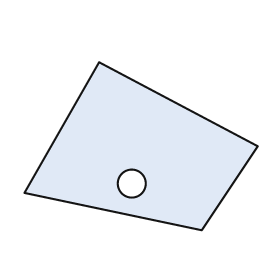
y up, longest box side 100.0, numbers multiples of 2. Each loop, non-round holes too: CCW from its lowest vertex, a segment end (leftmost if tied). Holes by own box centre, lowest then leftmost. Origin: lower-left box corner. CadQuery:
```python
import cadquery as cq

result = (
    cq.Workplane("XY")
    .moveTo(76.0, 0.0)
    .lineTo(100.0, 36.0)
    .lineTo(32.0, 72.0)
    .lineTo(0.0, 16.0)
    .close()
    .moveTo(46.0, 20.0)
    .circle(6.0)
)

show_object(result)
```